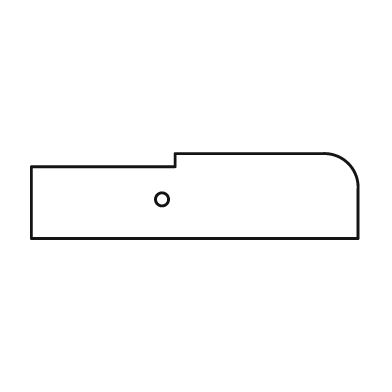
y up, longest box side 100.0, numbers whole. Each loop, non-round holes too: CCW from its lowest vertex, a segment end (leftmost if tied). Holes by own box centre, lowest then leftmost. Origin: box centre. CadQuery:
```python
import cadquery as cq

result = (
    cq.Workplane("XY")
    .moveTo(-50.0, -13.0)
    .lineTo(50.0, -13.0)
    .lineTo(50.0, 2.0)
    .threePointArc((47.0, 10.0), (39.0, 13.0))
    .lineTo(-6.0, 13.0)
    .lineTo(-6.0, 9.0)
    .lineTo(-50.0, 9.0)
    .close()
    .moveTo(-10.0, -1.0)
    .circle(2.0)
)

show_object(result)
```